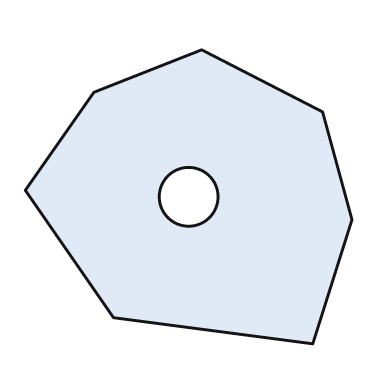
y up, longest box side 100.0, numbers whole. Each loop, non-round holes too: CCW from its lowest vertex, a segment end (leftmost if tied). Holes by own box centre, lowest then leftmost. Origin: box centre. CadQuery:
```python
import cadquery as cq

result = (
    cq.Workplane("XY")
    .moveTo(38.0, -45.0)
    .lineTo(50.0, -7.0)
    .lineTo(41.0, 26.0)
    .lineTo(4.0, 45.0)
    .lineTo(-29.0, 32.0)
    .lineTo(-50.0, 2.0)
    .lineTo(-23.0, -37.0)
    .close()
    .moveTo(0.0, 0.0)
    .circle(9.0)
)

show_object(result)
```